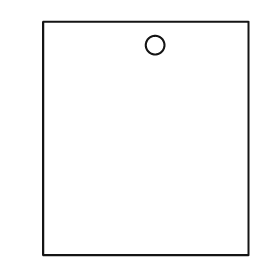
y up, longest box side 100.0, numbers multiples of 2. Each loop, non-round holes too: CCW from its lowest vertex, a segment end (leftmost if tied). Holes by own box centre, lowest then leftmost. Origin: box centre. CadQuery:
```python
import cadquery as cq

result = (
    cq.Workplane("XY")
    .moveTo(-44.0, -50.0)
    .lineTo(44.0, -50.0)
    .lineTo(44.0, 50.0)
    .lineTo(-44.0, 50.0)
    .close()
    .moveTo(4.0, 40.0)
    .circle(4.0)
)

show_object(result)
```